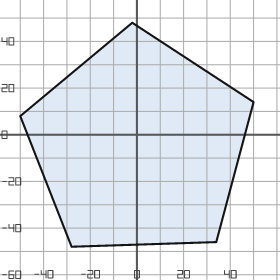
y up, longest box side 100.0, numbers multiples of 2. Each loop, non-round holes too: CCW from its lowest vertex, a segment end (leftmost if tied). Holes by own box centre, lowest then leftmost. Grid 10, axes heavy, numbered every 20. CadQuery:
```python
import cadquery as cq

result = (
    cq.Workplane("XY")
    .moveTo(-28.0, -48.0)
    .lineTo(34.0, -46.0)
    .lineTo(50.0, 14.0)
    .lineTo(-2.0, 48.0)
    .lineTo(-50.0, 8.0)
    .close()
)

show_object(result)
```